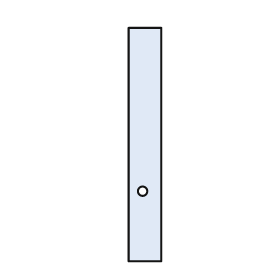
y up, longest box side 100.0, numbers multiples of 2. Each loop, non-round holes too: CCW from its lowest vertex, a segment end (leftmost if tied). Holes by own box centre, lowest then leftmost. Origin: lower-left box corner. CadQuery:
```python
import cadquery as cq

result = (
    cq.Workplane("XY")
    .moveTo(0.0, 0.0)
    .lineTo(14.0, 0.0)
    .lineTo(14.0, 100.0)
    .lineTo(0.0, 100.0)
    .close()
    .moveTo(6.0, 30.0)
    .circle(2.0)
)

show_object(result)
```